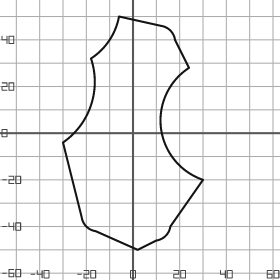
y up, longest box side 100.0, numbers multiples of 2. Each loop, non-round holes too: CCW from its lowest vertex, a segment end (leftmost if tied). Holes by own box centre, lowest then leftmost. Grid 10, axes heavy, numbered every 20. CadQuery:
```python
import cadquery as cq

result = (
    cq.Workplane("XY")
    .moveTo(2.0, -50.0)
    .lineTo(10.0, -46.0)
    .threePointArc((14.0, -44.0), (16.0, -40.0))
    .lineTo(30.0, -20.0)
    .threePointArc((12.0, 2.0), (24.0, 28.0))
    .lineTo(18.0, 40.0)
    .threePointArc((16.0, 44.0), (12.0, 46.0))
    .lineTo(-6.0, 50.0)
    .threePointArc((-10.0, 40.0), (-18.0, 32.0))
    .threePointArc((-18.0, 12.0), (-30.0, -4.0))
    .lineTo(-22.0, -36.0)
    .threePointArc((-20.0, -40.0), (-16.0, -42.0))
    .close()
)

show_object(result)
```